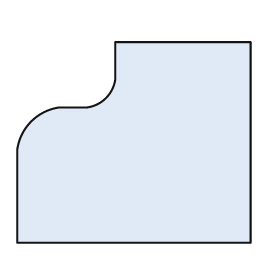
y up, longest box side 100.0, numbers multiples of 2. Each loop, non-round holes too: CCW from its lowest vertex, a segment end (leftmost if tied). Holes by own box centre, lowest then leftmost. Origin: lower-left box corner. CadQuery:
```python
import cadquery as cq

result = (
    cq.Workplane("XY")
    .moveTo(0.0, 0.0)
    .lineTo(100.0, 0.0)
    .lineTo(100.0, 86.0)
    .lineTo(42.0, 86.0)
    .lineTo(42.0, 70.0)
    .threePointArc((38.0, 62.0), (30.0, 58.0))
    .lineTo(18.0, 58.0)
    .threePointArc((6.0, 52.0), (0.0, 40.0))
    .close()
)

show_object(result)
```